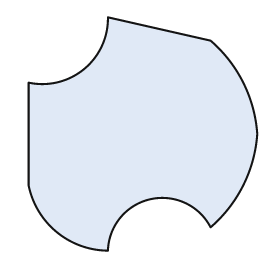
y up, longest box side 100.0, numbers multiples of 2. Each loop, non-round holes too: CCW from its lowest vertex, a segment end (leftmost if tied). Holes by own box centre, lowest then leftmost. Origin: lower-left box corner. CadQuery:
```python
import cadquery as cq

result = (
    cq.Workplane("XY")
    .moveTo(34.0, 0.0)
    .threePointArc((52.0, 22.0), (78.0, 10.0))
    .threePointArc((92.0, 28.0), (98.0, 50.0))
    .threePointArc((92.0, 72.0), (78.0, 90.0))
    .lineTo(34.0, 100.0)
    .threePointArc((24.0, 78.0), (0.0, 72.0))
    .lineTo(0.0, 28.0)
    .threePointArc((12.0, 8.0), (34.0, 0.0))
    .close()
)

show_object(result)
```